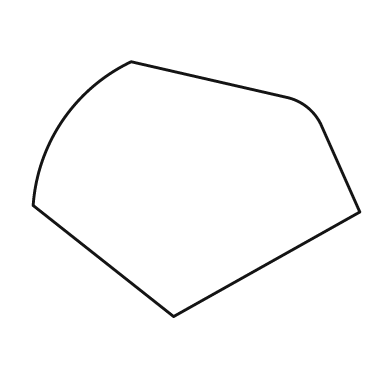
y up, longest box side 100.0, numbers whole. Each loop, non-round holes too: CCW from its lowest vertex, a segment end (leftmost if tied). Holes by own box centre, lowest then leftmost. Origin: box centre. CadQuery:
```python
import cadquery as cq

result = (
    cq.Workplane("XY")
    .moveTo(-7.0, -39.0)
    .lineTo(50.0, -7.0)
    .lineTo(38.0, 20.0)
    .threePointArc((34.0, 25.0), (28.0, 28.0))
    .lineTo(-20.0, 39.0)
    .threePointArc((-41.0, 21.0), (-50.0, -5.0))
    .close()
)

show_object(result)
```